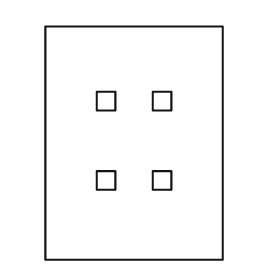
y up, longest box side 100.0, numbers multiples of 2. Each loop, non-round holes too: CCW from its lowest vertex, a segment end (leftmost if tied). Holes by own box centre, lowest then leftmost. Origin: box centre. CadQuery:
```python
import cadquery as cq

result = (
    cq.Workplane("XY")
    .moveTo(-38.0, -50.0)
    .lineTo(38.0, -50.0)
    .lineTo(38.0, 50.0)
    .lineTo(-38.0, 50.0)
    .close()
    .moveTo(-16.0, -20.0)
    .lineTo(-8.0, -20.0)
    .lineTo(-8.0, -12.0)
    .lineTo(-16.0, -12.0)
    .close()
    .moveTo(8.0, -20.0)
    .lineTo(16.0, -20.0)
    .lineTo(16.0, -12.0)
    .lineTo(8.0, -12.0)
    .close()
    .moveTo(-16.0, 14.0)
    .lineTo(-8.0, 14.0)
    .lineTo(-8.0, 22.0)
    .lineTo(-16.0, 22.0)
    .close()
    .moveTo(8.0, 14.0)
    .lineTo(16.0, 14.0)
    .lineTo(16.0, 22.0)
    .lineTo(8.0, 22.0)
    .close()
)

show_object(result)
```